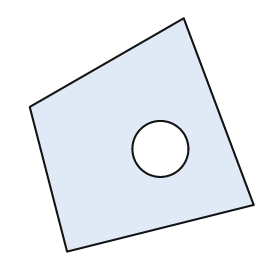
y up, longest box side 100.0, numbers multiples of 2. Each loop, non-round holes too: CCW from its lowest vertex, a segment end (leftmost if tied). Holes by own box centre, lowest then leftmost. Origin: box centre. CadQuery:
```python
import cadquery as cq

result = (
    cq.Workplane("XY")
    .moveTo(-32.0, -50.0)
    .lineTo(48.0, -30.0)
    .lineTo(18.0, 50.0)
    .lineTo(-48.0, 12.0)
    .close()
    .moveTo(8.0, -6.0)
    .circle(12.0)
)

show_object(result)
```